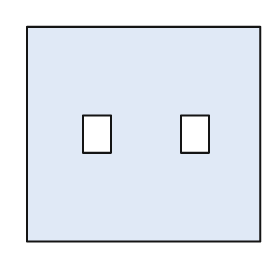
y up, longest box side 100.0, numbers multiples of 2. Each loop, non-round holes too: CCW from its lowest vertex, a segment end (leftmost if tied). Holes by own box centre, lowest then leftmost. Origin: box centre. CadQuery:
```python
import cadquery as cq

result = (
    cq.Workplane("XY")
    .moveTo(-50.0, -46.0)
    .lineTo(50.0, -46.0)
    .lineTo(50.0, 46.0)
    .lineTo(-50.0, 46.0)
    .close()
    .moveTo(-26.0, -8.0)
    .lineTo(-14.0, -8.0)
    .lineTo(-14.0, 8.0)
    .lineTo(-26.0, 8.0)
    .close()
    .moveTo(16.0, -8.0)
    .lineTo(28.0, -8.0)
    .lineTo(28.0, 8.0)
    .lineTo(16.0, 8.0)
    .close()
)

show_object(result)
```